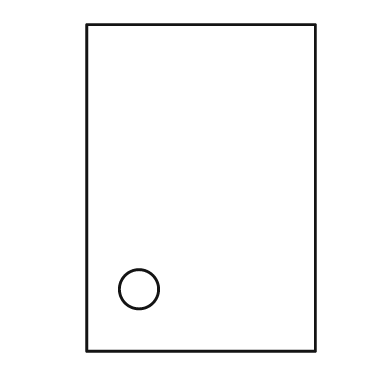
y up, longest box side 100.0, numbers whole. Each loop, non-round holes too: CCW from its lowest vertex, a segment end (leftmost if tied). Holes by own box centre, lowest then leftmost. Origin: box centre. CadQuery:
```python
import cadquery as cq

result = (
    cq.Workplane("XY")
    .moveTo(-35.0, -50.0)
    .lineTo(35.0, -50.0)
    .lineTo(35.0, 50.0)
    .lineTo(-35.0, 50.0)
    .close()
    .moveTo(-19.0, -31.0)
    .circle(6.0)
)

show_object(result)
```